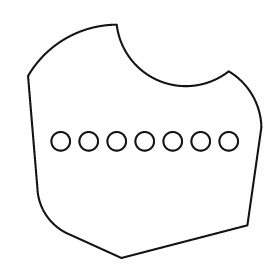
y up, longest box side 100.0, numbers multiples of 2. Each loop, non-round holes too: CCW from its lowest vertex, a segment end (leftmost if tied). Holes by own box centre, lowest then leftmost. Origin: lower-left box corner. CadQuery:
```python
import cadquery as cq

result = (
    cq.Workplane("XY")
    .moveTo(40.0, 0.0)
    .lineTo(94.0, 14.0)
    .lineTo(100.0, 56.0)
    .threePointArc((96.0, 70.0), (86.0, 80.0))
    .threePointArc((56.0, 76.0), (38.0, 100.0))
    .threePointArc((16.0, 94.0), (0.0, 78.0))
    .lineTo(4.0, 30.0)
    .threePointArc((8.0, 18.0), (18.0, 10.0))
    .close()
    .moveTo(14.0, 50.0)
    .circle(4.0)
    .moveTo(26.0, 50.0)
    .circle(4.0)
    .moveTo(38.0, 50.0)
    .circle(4.0)
    .moveTo(50.0, 50.0)
    .circle(4.0)
    .moveTo(62.0, 50.0)
    .circle(4.0)
    .moveTo(74.0, 50.0)
    .circle(4.0)
    .moveTo(86.0, 50.0)
    .circle(4.0)
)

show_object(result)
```